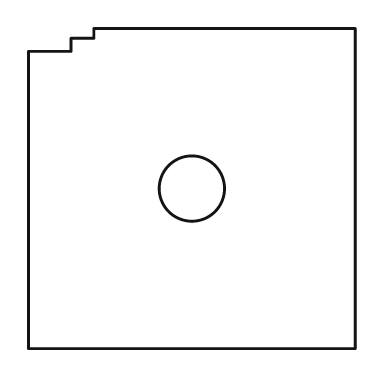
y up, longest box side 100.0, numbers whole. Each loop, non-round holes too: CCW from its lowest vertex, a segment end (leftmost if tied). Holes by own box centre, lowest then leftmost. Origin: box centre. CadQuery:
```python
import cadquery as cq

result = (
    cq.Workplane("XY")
    .moveTo(-50.0, -49.0)
    .lineTo(50.0, -49.0)
    .lineTo(50.0, 49.0)
    .lineTo(-30.0, 49.0)
    .lineTo(-30.0, 46.0)
    .lineTo(-37.0, 46.0)
    .lineTo(-37.0, 42.0)
    .lineTo(-50.0, 42.0)
    .close()
    .moveTo(0.0, 0.0)
    .circle(10.0)
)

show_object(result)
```